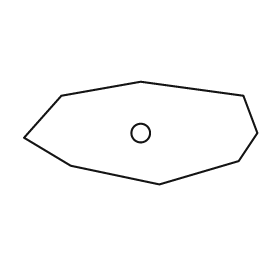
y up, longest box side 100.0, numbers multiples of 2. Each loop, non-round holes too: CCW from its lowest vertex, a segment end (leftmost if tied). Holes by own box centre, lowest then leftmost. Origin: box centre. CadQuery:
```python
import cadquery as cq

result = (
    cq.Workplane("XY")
    .moveTo(8.0, -22.0)
    .lineTo(42.0, -12.0)
    .lineTo(50.0, 0.0)
    .lineTo(44.0, 16.0)
    .lineTo(0.0, 22.0)
    .lineTo(-34.0, 16.0)
    .lineTo(-50.0, -2.0)
    .lineTo(-30.0, -14.0)
    .close()
    .moveTo(0.0, 0.0)
    .circle(4.0)
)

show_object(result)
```